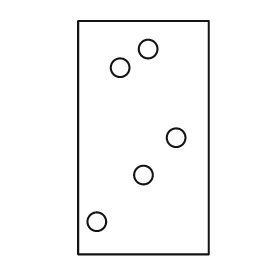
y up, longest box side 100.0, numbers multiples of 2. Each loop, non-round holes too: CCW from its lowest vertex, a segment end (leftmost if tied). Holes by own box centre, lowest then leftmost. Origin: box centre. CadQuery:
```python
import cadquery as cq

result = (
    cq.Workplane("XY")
    .moveTo(-28.0, -50.0)
    .lineTo(28.0, -50.0)
    .lineTo(28.0, 50.0)
    .lineTo(-28.0, 50.0)
    .close()
    .moveTo(-20.0, -36.0)
    .circle(4.0)
    .moveTo(0.0, -16.0)
    .circle(4.0)
    .moveTo(14.0, 0.0)
    .circle(4.0)
    .moveTo(-10.0, 30.0)
    .circle(4.0)
    .moveTo(2.0, 38.0)
    .circle(4.0)
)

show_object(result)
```